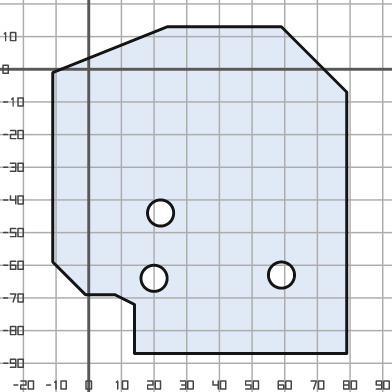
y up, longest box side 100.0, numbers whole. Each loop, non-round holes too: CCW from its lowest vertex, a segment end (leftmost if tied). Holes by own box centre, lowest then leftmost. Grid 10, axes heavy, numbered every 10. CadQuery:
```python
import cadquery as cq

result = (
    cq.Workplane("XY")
    .moveTo(14.0, -87.0)
    .lineTo(79.0, -87.0)
    .lineTo(79.0, -7.0)
    .lineTo(59.0, 13.0)
    .lineTo(24.0, 13.0)
    .lineTo(-11.0, -1.0)
    .lineTo(-11.0, -59.0)
    .lineTo(-1.0, -69.0)
    .lineTo(8.0, -69.0)
    .lineTo(14.0, -72.0)
    .close()
    .moveTo(20.0, -64.0)
    .circle(4.0)
    .moveTo(59.0, -63.0)
    .circle(4.0)
    .moveTo(22.0, -44.0)
    .circle(4.0)
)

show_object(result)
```